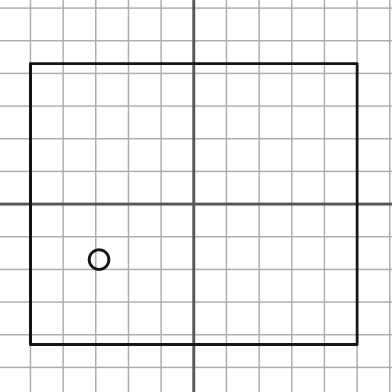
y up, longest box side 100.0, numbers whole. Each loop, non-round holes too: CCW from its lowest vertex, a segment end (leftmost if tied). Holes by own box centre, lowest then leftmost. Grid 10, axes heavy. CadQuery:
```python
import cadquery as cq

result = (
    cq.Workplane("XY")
    .moveTo(-50.0, -43.0)
    .lineTo(50.0, -43.0)
    .lineTo(50.0, 43.0)
    .lineTo(-50.0, 43.0)
    .close()
    .moveTo(-29.0, -17.0)
    .circle(3.0)
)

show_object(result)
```